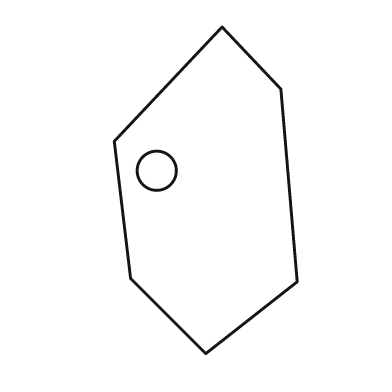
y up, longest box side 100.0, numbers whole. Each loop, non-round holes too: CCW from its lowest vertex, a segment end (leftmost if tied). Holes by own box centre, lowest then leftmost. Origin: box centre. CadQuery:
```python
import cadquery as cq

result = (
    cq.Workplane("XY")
    .moveTo(0.0, -50.0)
    .lineTo(28.0, -28.0)
    .lineTo(23.0, 31.0)
    .lineTo(5.0, 50.0)
    .lineTo(-28.0, 15.0)
    .lineTo(-23.0, -27.0)
    .close()
    .moveTo(-15.0, 6.0)
    .circle(6.0)
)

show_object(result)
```